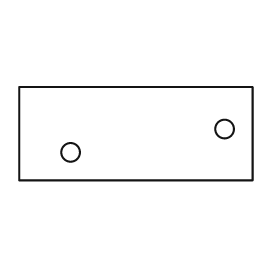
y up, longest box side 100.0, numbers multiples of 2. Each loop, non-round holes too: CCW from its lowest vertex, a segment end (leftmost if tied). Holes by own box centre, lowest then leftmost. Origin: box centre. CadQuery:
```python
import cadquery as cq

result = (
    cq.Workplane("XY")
    .moveTo(-50.0, -20.0)
    .lineTo(50.0, -20.0)
    .lineTo(50.0, 20.0)
    .lineTo(-50.0, 20.0)
    .close()
    .moveTo(-28.0, -8.0)
    .circle(4.0)
    .moveTo(38.0, 2.0)
    .circle(4.0)
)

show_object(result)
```